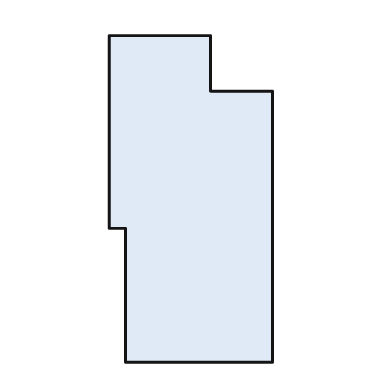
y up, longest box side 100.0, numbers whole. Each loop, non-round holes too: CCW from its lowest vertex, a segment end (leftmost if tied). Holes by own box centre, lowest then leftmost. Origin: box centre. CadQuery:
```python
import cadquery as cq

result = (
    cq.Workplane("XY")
    .moveTo(-20.0, -50.0)
    .lineTo(25.0, -50.0)
    .lineTo(25.0, 33.0)
    .lineTo(6.0, 33.0)
    .lineTo(6.0, 50.0)
    .lineTo(-25.0, 50.0)
    .lineTo(-25.0, -9.0)
    .lineTo(-20.0, -9.0)
    .close()
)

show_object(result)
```